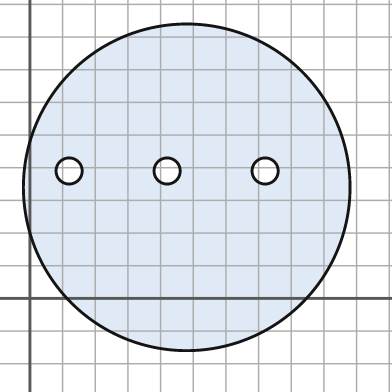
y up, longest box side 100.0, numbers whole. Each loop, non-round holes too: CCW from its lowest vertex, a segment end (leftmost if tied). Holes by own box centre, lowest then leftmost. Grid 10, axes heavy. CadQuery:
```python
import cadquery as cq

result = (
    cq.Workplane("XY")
    .moveTo(48.0, 34.0)
    .circle(50.0)
    .moveTo(12.0, 39.0)
    .circle(4.0)
    .moveTo(42.0, 39.0)
    .circle(4.0)
    .moveTo(72.0, 39.0)
    .circle(4.0)
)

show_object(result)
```